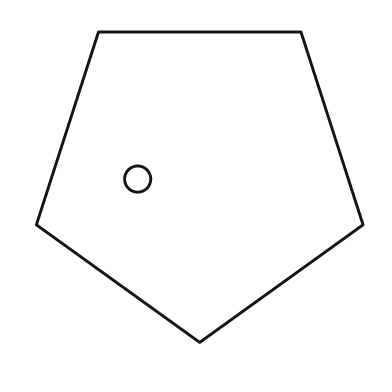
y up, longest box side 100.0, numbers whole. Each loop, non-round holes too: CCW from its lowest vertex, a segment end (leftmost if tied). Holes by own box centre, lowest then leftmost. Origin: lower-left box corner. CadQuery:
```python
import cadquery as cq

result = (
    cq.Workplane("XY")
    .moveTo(50.0, 0.0)
    .lineTo(100.0, 36.0)
    .lineTo(81.0, 95.0)
    .lineTo(19.0, 95.0)
    .lineTo(0.0, 36.0)
    .close()
    .moveTo(31.0, 50.0)
    .circle(4.0)
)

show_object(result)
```